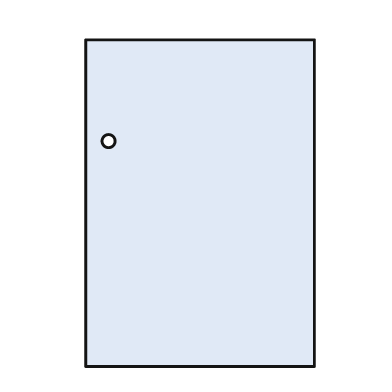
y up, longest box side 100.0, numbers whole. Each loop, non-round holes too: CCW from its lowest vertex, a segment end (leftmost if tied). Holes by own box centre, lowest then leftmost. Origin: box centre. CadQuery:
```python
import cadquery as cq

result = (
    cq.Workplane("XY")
    .moveTo(-35.0, -50.0)
    .lineTo(35.0, -50.0)
    .lineTo(35.0, 50.0)
    .lineTo(-35.0, 50.0)
    .close()
    .moveTo(-28.0, 19.0)
    .circle(2.0)
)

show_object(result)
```